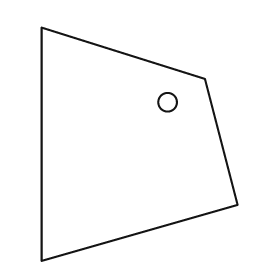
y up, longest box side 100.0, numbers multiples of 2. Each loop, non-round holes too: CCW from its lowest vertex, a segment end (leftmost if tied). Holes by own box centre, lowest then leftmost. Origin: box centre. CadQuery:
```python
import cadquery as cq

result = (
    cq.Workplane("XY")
    .moveTo(-42.0, -50.0)
    .lineTo(42.0, -26.0)
    .lineTo(28.0, 28.0)
    .lineTo(-42.0, 50.0)
    .close()
    .moveTo(12.0, 18.0)
    .circle(4.0)
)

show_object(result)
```